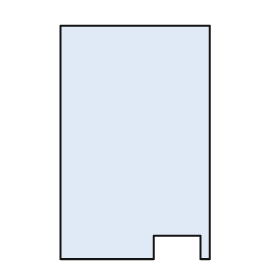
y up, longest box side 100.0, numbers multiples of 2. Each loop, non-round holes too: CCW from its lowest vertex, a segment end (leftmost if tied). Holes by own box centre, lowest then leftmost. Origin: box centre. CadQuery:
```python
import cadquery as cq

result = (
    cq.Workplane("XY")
    .moveTo(-32.0, -50.0)
    .lineTo(8.0, -50.0)
    .lineTo(8.0, -40.0)
    .lineTo(28.0, -40.0)
    .lineTo(28.0, -50.0)
    .lineTo(32.0, -50.0)
    .lineTo(32.0, 50.0)
    .lineTo(-32.0, 50.0)
    .close()
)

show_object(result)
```